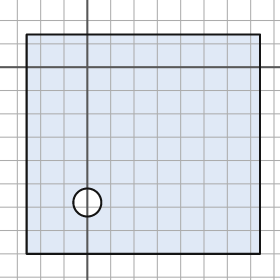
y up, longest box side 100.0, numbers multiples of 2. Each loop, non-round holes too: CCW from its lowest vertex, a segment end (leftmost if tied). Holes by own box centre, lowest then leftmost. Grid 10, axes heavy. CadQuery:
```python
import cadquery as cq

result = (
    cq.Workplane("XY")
    .moveTo(-26.0, -80.0)
    .lineTo(74.0, -80.0)
    .lineTo(74.0, 14.0)
    .lineTo(-26.0, 14.0)
    .close()
    .moveTo(0.0, -58.0)
    .circle(6.0)
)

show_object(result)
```